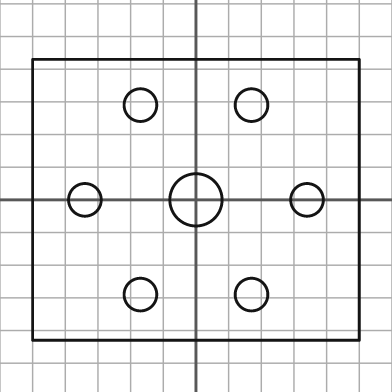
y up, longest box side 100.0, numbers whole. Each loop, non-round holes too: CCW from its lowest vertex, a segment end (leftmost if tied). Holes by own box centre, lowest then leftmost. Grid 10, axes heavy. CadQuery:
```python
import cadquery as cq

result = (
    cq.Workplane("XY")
    .moveTo(-50.0, -43.0)
    .lineTo(50.0, -43.0)
    .lineTo(50.0, 43.0)
    .lineTo(-50.0, 43.0)
    .close()
    .moveTo(-17.0, -29.0)
    .circle(5.0)
    .moveTo(17.0, -29.0)
    .circle(5.0)
    .moveTo(-34.0, 0.0)
    .circle(5.0)
    .moveTo(0.0, 0.0)
    .circle(8.0)
    .moveTo(34.0, 0.0)
    .circle(5.0)
    .moveTo(-17.0, 29.0)
    .circle(5.0)
    .moveTo(17.0, 29.0)
    .circle(5.0)
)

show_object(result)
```